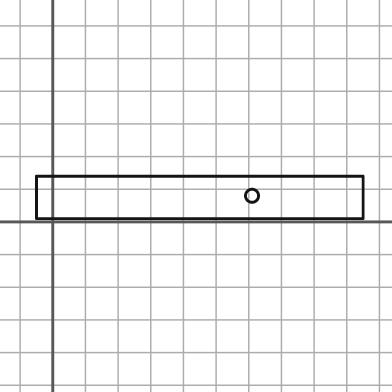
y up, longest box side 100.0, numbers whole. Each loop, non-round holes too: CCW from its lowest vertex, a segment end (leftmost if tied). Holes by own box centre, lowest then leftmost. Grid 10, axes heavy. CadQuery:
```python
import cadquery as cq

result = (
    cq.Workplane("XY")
    .moveTo(-5.0, 1.0)
    .lineTo(95.0, 1.0)
    .lineTo(95.0, 14.0)
    .lineTo(-5.0, 14.0)
    .close()
    .moveTo(61.0, 8.0)
    .circle(2.0)
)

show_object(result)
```